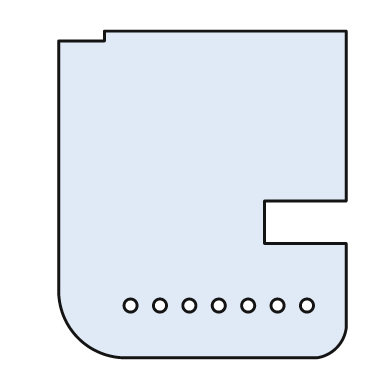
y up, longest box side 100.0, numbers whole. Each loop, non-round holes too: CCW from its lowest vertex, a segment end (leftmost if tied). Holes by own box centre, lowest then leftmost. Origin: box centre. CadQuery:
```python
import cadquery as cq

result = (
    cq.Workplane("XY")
    .moveTo(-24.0, -50.0)
    .lineTo(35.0, -50.0)
    .threePointArc((41.0, -47.0), (44.0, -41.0))
    .lineTo(44.0, -15.0)
    .lineTo(19.0, -15.0)
    .lineTo(19.0, -2.0)
    .lineTo(44.0, -2.0)
    .lineTo(44.0, 50.0)
    .lineTo(-30.0, 50.0)
    .lineTo(-30.0, 47.0)
    .lineTo(-44.0, 47.0)
    .lineTo(-44.0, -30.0)
    .threePointArc((-38.0, -44.0), (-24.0, -50.0))
    .close()
    .moveTo(-22.0, -34.0)
    .circle(2.0)
    .moveTo(-13.0, -34.0)
    .circle(2.0)
    .moveTo(-4.0, -34.0)
    .circle(2.0)
    .moveTo(5.0, -34.0)
    .circle(2.0)
    .moveTo(14.0, -34.0)
    .circle(2.0)
    .moveTo(23.0, -34.0)
    .circle(2.0)
    .moveTo(32.0, -34.0)
    .circle(2.0)
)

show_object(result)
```